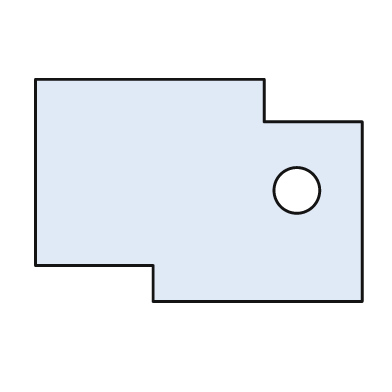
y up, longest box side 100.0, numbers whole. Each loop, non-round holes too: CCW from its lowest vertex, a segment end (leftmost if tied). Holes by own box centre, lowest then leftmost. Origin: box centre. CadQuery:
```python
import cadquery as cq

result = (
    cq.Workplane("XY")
    .moveTo(-14.0, -34.0)
    .lineTo(50.0, -34.0)
    .lineTo(50.0, 21.0)
    .lineTo(20.0, 21.0)
    .lineTo(20.0, 34.0)
    .lineTo(-50.0, 34.0)
    .lineTo(-50.0, -23.0)
    .lineTo(-14.0, -23.0)
    .close()
    .moveTo(30.0, 0.0)
    .circle(7.0)
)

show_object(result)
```